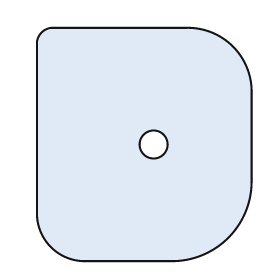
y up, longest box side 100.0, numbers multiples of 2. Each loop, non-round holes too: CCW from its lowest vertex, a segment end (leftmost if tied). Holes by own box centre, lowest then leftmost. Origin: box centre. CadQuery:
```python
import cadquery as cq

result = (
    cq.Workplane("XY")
    .moveTo(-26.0, -50.0)
    .lineTo(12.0, -50.0)
    .threePointArc((36.0, -40.0), (46.0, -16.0))
    .lineTo(46.0, 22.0)
    .threePointArc((38.0, 42.0), (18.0, 50.0))
    .lineTo(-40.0, 50.0)
    .threePointArc((-44.0, 48.0), (-46.0, 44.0))
    .lineTo(-46.0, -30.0)
    .threePointArc((-40.0, -44.0), (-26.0, -50.0))
    .close()
    .moveTo(4.0, 0.0)
    .circle(6.0)
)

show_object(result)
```